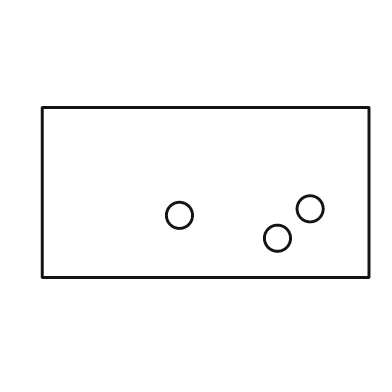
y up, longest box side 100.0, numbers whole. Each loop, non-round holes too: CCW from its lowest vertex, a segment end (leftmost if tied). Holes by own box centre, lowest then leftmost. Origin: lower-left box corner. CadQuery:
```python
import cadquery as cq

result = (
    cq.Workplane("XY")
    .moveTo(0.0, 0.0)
    .lineTo(100.0, 0.0)
    .lineTo(100.0, 52.0)
    .lineTo(0.0, 52.0)
    .close()
    .moveTo(72.0, 12.0)
    .circle(4.0)
    .moveTo(42.0, 19.0)
    .circle(4.0)
    .moveTo(82.0, 21.0)
    .circle(4.0)
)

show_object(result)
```